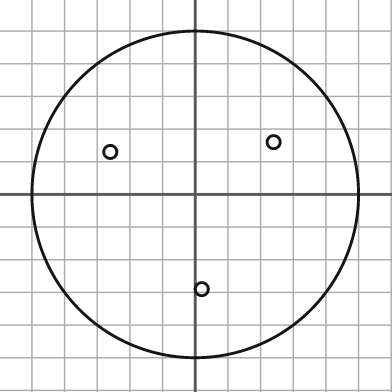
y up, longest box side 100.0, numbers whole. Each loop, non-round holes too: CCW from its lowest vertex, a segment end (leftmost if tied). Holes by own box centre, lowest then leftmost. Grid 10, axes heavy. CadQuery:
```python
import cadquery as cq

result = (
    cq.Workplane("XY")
    .moveTo(0.0, 0.0)
    .circle(50.0)
    .moveTo(2.0, -29.0)
    .circle(2.0)
    .moveTo(-26.0, 13.0)
    .circle(2.0)
    .moveTo(24.0, 16.0)
    .circle(2.0)
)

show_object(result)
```